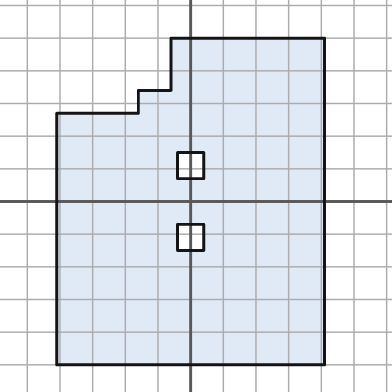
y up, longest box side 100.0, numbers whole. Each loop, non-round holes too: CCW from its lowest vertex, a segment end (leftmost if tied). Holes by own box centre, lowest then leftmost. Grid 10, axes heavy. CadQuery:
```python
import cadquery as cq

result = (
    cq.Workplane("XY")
    .moveTo(-41.0, -50.0)
    .lineTo(41.0, -50.0)
    .lineTo(41.0, 50.0)
    .lineTo(-6.0, 50.0)
    .lineTo(-6.0, 34.0)
    .lineTo(-16.0, 34.0)
    .lineTo(-16.0, 27.0)
    .lineTo(-41.0, 27.0)
    .close()
    .moveTo(-4.0, -15.0)
    .lineTo(4.0, -15.0)
    .lineTo(4.0, -7.0)
    .lineTo(-4.0, -7.0)
    .close()
    .moveTo(-4.0, 7.0)
    .lineTo(4.0, 7.0)
    .lineTo(4.0, 15.0)
    .lineTo(-4.0, 15.0)
    .close()
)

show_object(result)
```